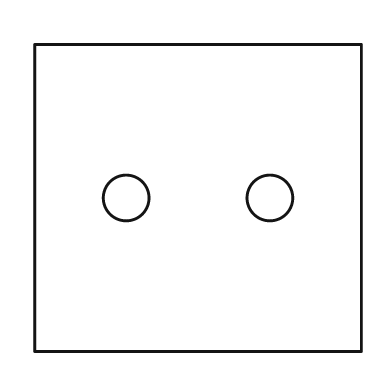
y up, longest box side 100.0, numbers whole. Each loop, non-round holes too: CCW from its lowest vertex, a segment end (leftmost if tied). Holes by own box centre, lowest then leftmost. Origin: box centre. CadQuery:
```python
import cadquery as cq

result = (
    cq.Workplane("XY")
    .moveTo(-50.0, -47.0)
    .lineTo(50.0, -47.0)
    .lineTo(50.0, 47.0)
    .lineTo(-50.0, 47.0)
    .close()
    .moveTo(-22.0, 0.0)
    .circle(7.0)
    .moveTo(22.0, 0.0)
    .circle(7.0)
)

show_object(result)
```